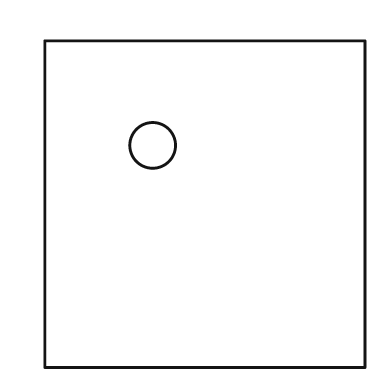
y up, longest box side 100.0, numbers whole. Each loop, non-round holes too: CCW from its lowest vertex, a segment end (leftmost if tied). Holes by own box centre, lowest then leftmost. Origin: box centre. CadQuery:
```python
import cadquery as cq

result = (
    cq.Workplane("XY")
    .moveTo(-49.0, -50.0)
    .lineTo(49.0, -50.0)
    .lineTo(49.0, 50.0)
    .lineTo(-49.0, 50.0)
    .close()
    .moveTo(-16.0, 18.0)
    .circle(7.0)
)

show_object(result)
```